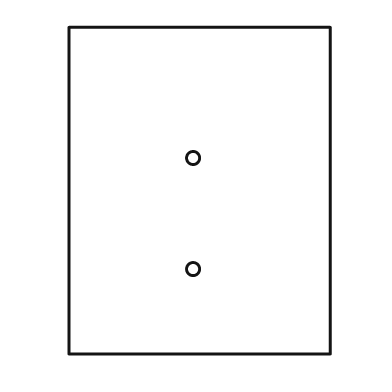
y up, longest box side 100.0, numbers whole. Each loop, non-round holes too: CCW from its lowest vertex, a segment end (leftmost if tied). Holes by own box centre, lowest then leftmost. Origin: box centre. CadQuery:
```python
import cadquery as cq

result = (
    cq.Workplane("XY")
    .moveTo(-40.0, -50.0)
    .lineTo(40.0, -50.0)
    .lineTo(40.0, 50.0)
    .lineTo(-40.0, 50.0)
    .close()
    .moveTo(-2.0, -24.0)
    .circle(2.0)
    .moveTo(-2.0, 10.0)
    .circle(2.0)
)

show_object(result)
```